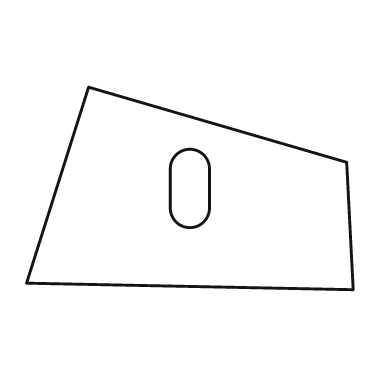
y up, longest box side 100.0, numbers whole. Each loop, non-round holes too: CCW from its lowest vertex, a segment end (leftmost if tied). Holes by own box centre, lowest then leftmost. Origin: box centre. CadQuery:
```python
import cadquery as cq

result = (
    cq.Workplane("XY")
    .moveTo(50.0, -31.0)
    .lineTo(48.0, 8.0)
    .lineTo(-31.0, 31.0)
    .lineTo(-50.0, -29.0)
    .close()
    .moveTo(-6.0, -6.0)
    .threePointArc((0.0, -12.0), (6.0, -6.0))
    .lineTo(6.0, 6.0)
    .threePointArc((0.0, 12.0), (-6.0, 6.0))
    .close()
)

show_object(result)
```